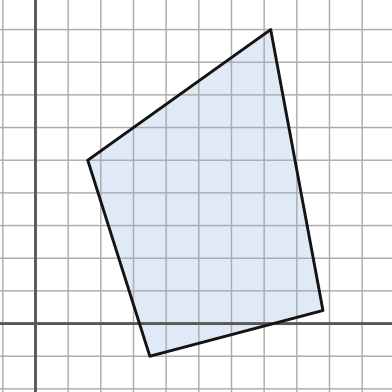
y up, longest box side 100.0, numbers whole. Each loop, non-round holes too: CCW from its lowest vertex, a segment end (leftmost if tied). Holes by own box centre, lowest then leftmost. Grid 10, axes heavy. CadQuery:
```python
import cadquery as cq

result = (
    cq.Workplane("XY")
    .moveTo(35.0, -10.0)
    .lineTo(88.0, 4.0)
    .lineTo(72.0, 90.0)
    .lineTo(16.0, 50.0)
    .close()
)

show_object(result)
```